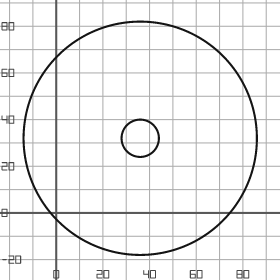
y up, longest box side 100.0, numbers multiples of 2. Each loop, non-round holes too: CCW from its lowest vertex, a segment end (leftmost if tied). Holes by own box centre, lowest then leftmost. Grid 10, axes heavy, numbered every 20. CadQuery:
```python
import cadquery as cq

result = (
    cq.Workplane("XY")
    .moveTo(36.0, 32.0)
    .circle(50.0)
    .moveTo(36.0, 32.0)
    .circle(8.0)
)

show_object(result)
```